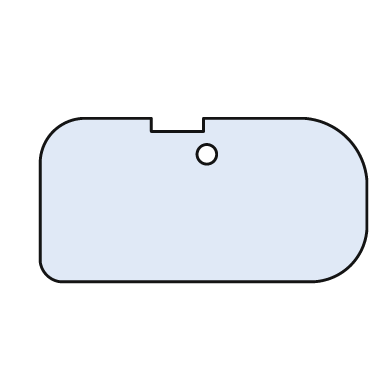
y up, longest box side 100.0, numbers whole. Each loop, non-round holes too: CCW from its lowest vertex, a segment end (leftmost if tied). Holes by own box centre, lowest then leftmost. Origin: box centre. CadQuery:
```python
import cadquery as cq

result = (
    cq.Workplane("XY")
    .moveTo(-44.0, -25.0)
    .lineTo(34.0, -25.0)
    .threePointArc((45.0, -20.0), (50.0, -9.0))
    .lineTo(50.0, 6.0)
    .threePointArc((44.0, 19.0), (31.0, 25.0))
    .lineTo(0.0, 25.0)
    .lineTo(0.0, 21.0)
    .lineTo(-16.0, 21.0)
    .lineTo(-16.0, 25.0)
    .lineTo(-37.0, 25.0)
    .threePointArc((-46.0, 21.0), (-50.0, 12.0))
    .lineTo(-50.0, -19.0)
    .threePointArc((-48.0, -23.0), (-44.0, -25.0))
    .close()
    .moveTo(1.0, 14.0)
    .circle(3.0)
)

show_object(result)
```